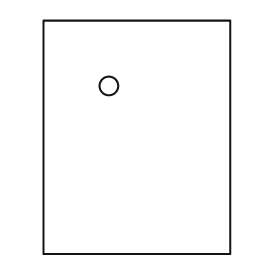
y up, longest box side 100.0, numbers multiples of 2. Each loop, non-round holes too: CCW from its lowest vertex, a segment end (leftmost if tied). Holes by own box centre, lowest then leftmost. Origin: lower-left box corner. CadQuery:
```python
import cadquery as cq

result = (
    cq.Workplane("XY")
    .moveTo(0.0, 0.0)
    .lineTo(80.0, 0.0)
    .lineTo(80.0, 100.0)
    .lineTo(0.0, 100.0)
    .close()
    .moveTo(28.0, 72.0)
    .circle(4.0)
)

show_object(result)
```